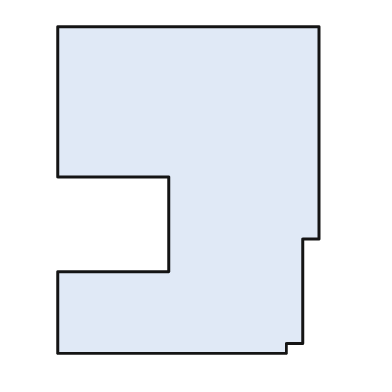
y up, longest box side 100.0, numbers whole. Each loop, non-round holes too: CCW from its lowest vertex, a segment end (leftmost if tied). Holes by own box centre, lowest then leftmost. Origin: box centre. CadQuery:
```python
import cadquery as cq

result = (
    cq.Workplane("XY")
    .moveTo(-40.0, -50.0)
    .lineTo(30.0, -50.0)
    .lineTo(30.0, -47.0)
    .lineTo(35.0, -47.0)
    .lineTo(35.0, -15.0)
    .lineTo(40.0, -15.0)
    .lineTo(40.0, 50.0)
    .lineTo(-40.0, 50.0)
    .lineTo(-40.0, 4.0)
    .lineTo(-6.0, 4.0)
    .lineTo(-6.0, -25.0)
    .lineTo(-40.0, -25.0)
    .close()
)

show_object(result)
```